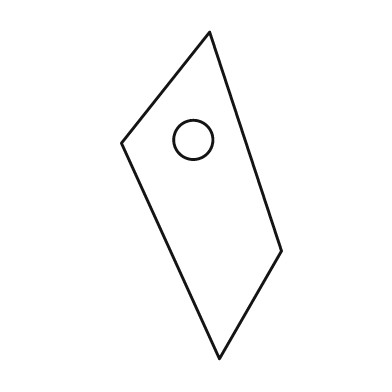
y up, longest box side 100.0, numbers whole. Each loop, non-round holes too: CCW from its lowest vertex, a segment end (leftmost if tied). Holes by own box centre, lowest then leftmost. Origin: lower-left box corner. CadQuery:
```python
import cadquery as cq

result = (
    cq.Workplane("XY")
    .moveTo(30.0, 0.0)
    .lineTo(49.0, 33.0)
    .lineTo(27.0, 100.0)
    .lineTo(0.0, 66.0)
    .close()
    .moveTo(22.0, 67.0)
    .circle(6.0)
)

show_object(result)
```